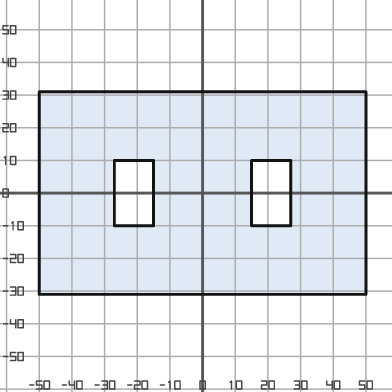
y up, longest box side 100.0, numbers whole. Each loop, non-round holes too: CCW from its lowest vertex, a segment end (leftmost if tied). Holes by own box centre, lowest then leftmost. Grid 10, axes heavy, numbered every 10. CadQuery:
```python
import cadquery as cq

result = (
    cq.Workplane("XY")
    .moveTo(-50.0, -31.0)
    .lineTo(50.0, -31.0)
    .lineTo(50.0, 31.0)
    .lineTo(-50.0, 31.0)
    .close()
    .moveTo(-27.0, -10.0)
    .lineTo(-15.0, -10.0)
    .lineTo(-15.0, 10.0)
    .lineTo(-27.0, 10.0)
    .close()
    .moveTo(15.0, -10.0)
    .lineTo(27.0, -10.0)
    .lineTo(27.0, 10.0)
    .lineTo(15.0, 10.0)
    .close()
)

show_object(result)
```